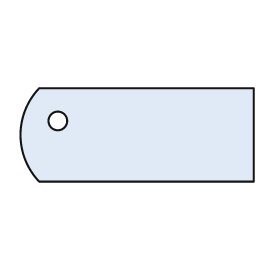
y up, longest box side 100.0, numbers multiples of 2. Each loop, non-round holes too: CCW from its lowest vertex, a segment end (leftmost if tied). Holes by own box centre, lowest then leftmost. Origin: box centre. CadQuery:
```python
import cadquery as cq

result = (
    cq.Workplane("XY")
    .moveTo(-42.0, -20.0)
    .lineTo(50.0, -20.0)
    .lineTo(50.0, 20.0)
    .lineTo(-42.0, 20.0)
    .threePointArc((-50.0, 0.0), (-42.0, -20.0))
    .close()
    .moveTo(-34.0, 6.0)
    .circle(4.0)
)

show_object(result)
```